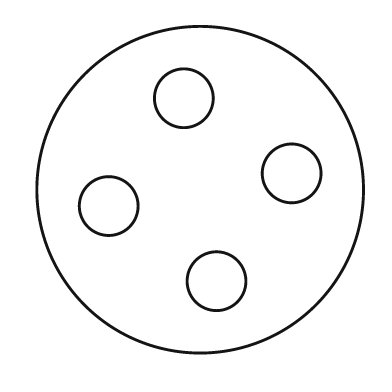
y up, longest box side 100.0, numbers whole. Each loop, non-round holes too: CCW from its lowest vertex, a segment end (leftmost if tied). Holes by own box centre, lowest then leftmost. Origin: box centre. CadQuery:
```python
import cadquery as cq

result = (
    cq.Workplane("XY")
    .moveTo(0.0, 0.0)
    .circle(50.0)
    .moveTo(5.0, -28.0)
    .circle(9.0)
    .moveTo(-28.0, -5.0)
    .circle(9.0)
    .moveTo(28.0, 5.0)
    .circle(9.0)
    .moveTo(-5.0, 28.0)
    .circle(9.0)
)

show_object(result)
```